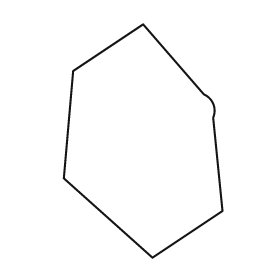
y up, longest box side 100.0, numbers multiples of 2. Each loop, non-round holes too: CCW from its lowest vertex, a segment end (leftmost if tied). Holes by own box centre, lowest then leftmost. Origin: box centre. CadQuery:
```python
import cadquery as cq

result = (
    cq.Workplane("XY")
    .moveTo(4.0, -50.0)
    .lineTo(34.0, -30.0)
    .lineTo(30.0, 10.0)
    .threePointArc((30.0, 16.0), (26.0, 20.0))
    .lineTo(0.0, 50.0)
    .lineTo(-30.0, 30.0)
    .lineTo(-34.0, -16.0)
    .close()
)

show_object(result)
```